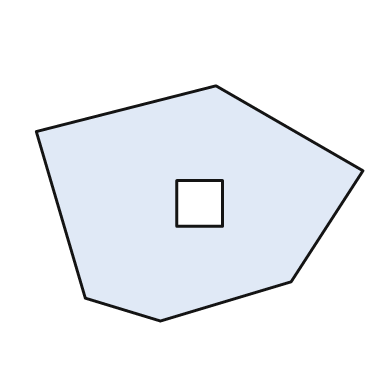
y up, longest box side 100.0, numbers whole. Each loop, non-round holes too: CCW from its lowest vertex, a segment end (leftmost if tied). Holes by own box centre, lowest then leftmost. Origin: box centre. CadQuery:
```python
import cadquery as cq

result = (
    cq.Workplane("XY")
    .moveTo(-12.0, -36.0)
    .lineTo(28.0, -24.0)
    .lineTo(50.0, 10.0)
    .lineTo(5.0, 36.0)
    .lineTo(-50.0, 22.0)
    .lineTo(-35.0, -29.0)
    .close()
    .moveTo(-7.0, -7.0)
    .lineTo(7.0, -7.0)
    .lineTo(7.0, 7.0)
    .lineTo(-7.0, 7.0)
    .close()
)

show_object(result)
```